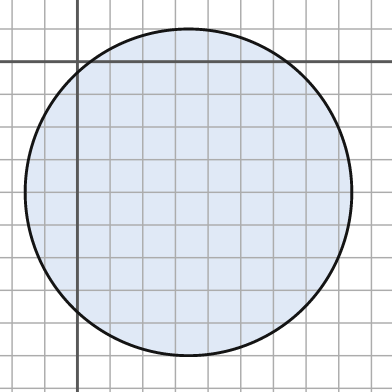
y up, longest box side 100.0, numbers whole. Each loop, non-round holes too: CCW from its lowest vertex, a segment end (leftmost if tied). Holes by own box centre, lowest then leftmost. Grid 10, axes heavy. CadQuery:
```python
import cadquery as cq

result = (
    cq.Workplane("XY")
    .moveTo(34.0, -40.0)
    .circle(50.0)
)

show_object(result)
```